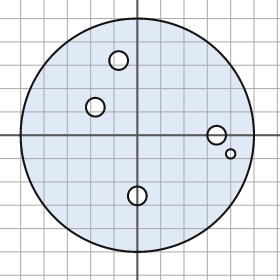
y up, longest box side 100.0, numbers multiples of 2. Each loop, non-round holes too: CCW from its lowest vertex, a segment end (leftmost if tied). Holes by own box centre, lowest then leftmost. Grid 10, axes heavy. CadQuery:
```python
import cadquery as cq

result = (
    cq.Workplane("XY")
    .moveTo(0.0, 0.0)
    .circle(50.0)
    .moveTo(0.0, -26.0)
    .circle(4.0)
    .moveTo(40.0, -8.0)
    .circle(2.0)
    .moveTo(34.0, 0.0)
    .circle(4.0)
    .moveTo(-18.0, 12.0)
    .circle(4.0)
    .moveTo(-8.0, 32.0)
    .circle(4.0)
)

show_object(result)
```